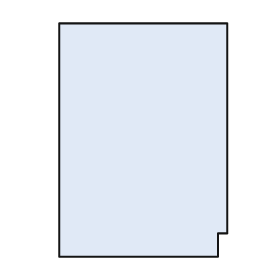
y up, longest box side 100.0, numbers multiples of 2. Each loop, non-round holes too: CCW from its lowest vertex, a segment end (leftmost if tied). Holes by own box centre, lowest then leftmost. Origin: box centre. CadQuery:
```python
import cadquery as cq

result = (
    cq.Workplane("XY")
    .moveTo(-36.0, -50.0)
    .lineTo(32.0, -50.0)
    .lineTo(32.0, -40.0)
    .lineTo(36.0, -40.0)
    .lineTo(36.0, 50.0)
    .lineTo(-36.0, 50.0)
    .close()
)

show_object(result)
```